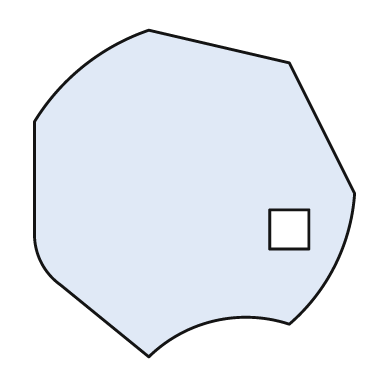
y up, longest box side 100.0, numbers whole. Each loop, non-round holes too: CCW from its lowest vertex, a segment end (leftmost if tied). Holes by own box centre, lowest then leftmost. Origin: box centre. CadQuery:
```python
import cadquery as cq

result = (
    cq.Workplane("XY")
    .moveTo(-14.0, -50.0)
    .threePointArc((6.0, -39.0), (29.0, -40.0))
    .threePointArc((43.0, -22.0), (49.0, 0.0))
    .lineTo(29.0, 40.0)
    .lineTo(-14.0, 50.0)
    .threePointArc((-34.0, 39.0), (-49.0, 22.0))
    .lineTo(-49.0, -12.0)
    .threePointArc((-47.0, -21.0), (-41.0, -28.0))
    .close()
    .moveTo(23.0, -17.0)
    .lineTo(35.0, -17.0)
    .lineTo(35.0, -5.0)
    .lineTo(23.0, -5.0)
    .close()
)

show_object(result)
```